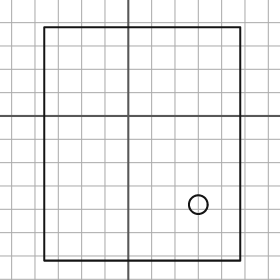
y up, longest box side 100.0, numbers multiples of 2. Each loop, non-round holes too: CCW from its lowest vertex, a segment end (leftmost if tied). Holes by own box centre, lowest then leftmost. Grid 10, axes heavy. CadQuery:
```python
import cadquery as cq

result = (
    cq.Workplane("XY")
    .moveTo(-36.0, -62.0)
    .lineTo(48.0, -62.0)
    .lineTo(48.0, 38.0)
    .lineTo(-36.0, 38.0)
    .close()
    .moveTo(30.0, -38.0)
    .circle(4.0)
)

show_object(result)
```